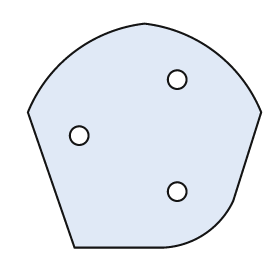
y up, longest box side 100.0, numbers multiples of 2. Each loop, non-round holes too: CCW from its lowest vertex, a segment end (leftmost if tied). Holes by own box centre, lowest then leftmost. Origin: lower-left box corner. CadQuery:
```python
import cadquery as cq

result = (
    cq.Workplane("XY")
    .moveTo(20.0, 0.0)
    .lineTo(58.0, 0.0)
    .threePointArc((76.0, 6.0), (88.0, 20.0))
    .lineTo(100.0, 58.0)
    .threePointArc((80.0, 84.0), (50.0, 96.0))
    .threePointArc((20.0, 84.0), (0.0, 58.0))
    .close()
    .moveTo(64.0, 24.0)
    .circle(4.0)
    .moveTo(22.0, 48.0)
    .circle(4.0)
    .moveTo(64.0, 72.0)
    .circle(4.0)
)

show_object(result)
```